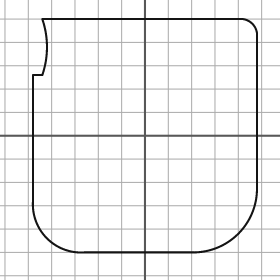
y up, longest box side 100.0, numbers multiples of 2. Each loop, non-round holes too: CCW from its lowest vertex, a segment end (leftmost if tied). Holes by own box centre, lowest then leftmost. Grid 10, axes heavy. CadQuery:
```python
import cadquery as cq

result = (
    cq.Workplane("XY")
    .moveTo(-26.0, -50.0)
    .lineTo(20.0, -50.0)
    .threePointArc((40.0, -42.0), (48.0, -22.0))
    .lineTo(48.0, 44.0)
    .threePointArc((46.0, 48.0), (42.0, 50.0))
    .lineTo(-44.0, 50.0)
    .threePointArc((-42.0, 38.0), (-44.0, 26.0))
    .lineTo(-48.0, 26.0)
    .lineTo(-48.0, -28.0)
    .threePointArc((-42.0, -44.0), (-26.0, -50.0))
    .close()
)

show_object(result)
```